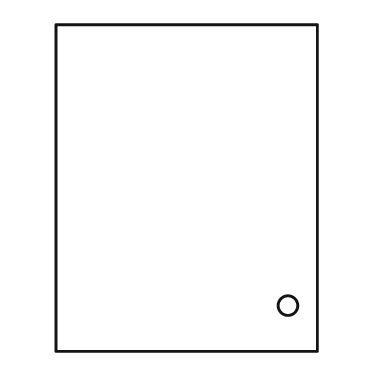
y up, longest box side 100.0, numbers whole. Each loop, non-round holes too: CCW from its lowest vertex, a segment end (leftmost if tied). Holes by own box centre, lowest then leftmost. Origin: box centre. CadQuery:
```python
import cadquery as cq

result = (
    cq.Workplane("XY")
    .moveTo(-40.0, -50.0)
    .lineTo(40.0, -50.0)
    .lineTo(40.0, 50.0)
    .lineTo(-40.0, 50.0)
    .close()
    .moveTo(31.0, -36.0)
    .circle(3.0)
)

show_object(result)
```